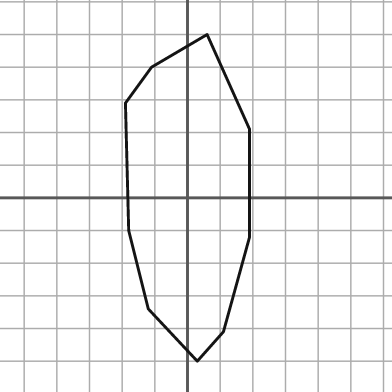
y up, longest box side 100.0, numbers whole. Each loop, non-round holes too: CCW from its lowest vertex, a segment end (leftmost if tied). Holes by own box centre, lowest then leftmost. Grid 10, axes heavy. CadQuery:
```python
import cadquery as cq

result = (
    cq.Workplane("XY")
    .moveTo(3.0, -50.0)
    .lineTo(11.0, -41.0)
    .lineTo(19.0, -12.0)
    .lineTo(19.0, 21.0)
    .lineTo(6.0, 50.0)
    .lineTo(-11.0, 40.0)
    .lineTo(-19.0, 29.0)
    .lineTo(-18.0, -10.0)
    .lineTo(-12.0, -34.0)
    .close()
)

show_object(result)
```